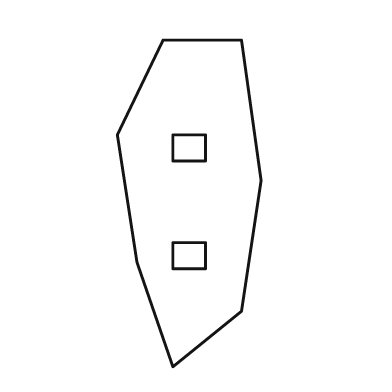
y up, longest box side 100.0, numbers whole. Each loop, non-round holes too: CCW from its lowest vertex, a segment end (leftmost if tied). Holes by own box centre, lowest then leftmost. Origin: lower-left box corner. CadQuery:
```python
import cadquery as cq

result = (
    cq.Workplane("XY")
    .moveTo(17.0, 0.0)
    .lineTo(38.0, 17.0)
    .lineTo(44.0, 57.0)
    .lineTo(38.0, 100.0)
    .lineTo(14.0, 100.0)
    .lineTo(0.0, 71.0)
    .lineTo(6.0, 32.0)
    .close()
    .moveTo(17.0, 30.0)
    .lineTo(27.0, 30.0)
    .lineTo(27.0, 38.0)
    .lineTo(17.0, 38.0)
    .close()
    .moveTo(17.0, 63.0)
    .lineTo(27.0, 63.0)
    .lineTo(27.0, 71.0)
    .lineTo(17.0, 71.0)
    .close()
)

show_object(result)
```